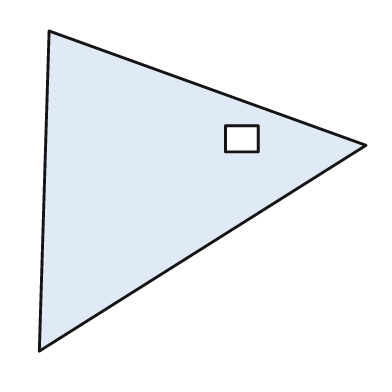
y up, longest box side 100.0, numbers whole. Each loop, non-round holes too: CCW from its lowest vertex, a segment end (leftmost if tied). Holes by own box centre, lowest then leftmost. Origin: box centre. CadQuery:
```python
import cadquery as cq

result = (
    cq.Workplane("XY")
    .moveTo(-50.0, -49.0)
    .lineTo(50.0, 14.0)
    .lineTo(-47.0, 49.0)
    .close()
    .moveTo(7.0, 12.0)
    .lineTo(17.0, 12.0)
    .lineTo(17.0, 20.0)
    .lineTo(7.0, 20.0)
    .close()
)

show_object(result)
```